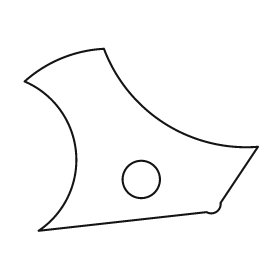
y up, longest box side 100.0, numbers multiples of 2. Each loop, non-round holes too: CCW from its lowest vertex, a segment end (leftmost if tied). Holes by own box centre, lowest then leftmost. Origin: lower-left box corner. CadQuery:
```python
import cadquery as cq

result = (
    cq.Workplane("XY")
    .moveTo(6.0, 0.0)
    .lineTo(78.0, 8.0)
    .threePointArc((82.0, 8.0), (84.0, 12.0))
    .lineTo(100.0, 36.0)
    .threePointArc((60.0, 46.0), (34.0, 78.0))
    .threePointArc((16.0, 74.0), (0.0, 64.0))
    .threePointArc((22.0, 34.0), (6.0, 0.0))
    .close()
    .moveTo(50.0, 22.0)
    .circle(8.0)
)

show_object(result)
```